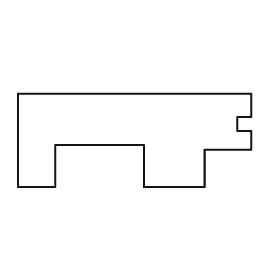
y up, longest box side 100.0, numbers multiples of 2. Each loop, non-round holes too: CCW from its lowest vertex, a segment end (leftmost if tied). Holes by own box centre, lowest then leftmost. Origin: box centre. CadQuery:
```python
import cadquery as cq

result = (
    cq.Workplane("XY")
    .moveTo(-50.0, -20.0)
    .lineTo(-34.0, -20.0)
    .lineTo(-34.0, -2.0)
    .lineTo(4.0, -2.0)
    .lineTo(4.0, -20.0)
    .lineTo(30.0, -20.0)
    .lineTo(30.0, -4.0)
    .lineTo(50.0, -4.0)
    .lineTo(50.0, 4.0)
    .lineTo(44.0, 4.0)
    .lineTo(44.0, 10.0)
    .lineTo(50.0, 10.0)
    .lineTo(50.0, 20.0)
    .lineTo(-50.0, 20.0)
    .close()
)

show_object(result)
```